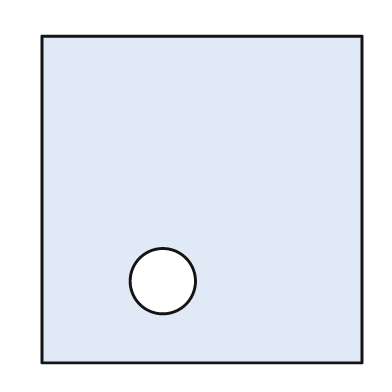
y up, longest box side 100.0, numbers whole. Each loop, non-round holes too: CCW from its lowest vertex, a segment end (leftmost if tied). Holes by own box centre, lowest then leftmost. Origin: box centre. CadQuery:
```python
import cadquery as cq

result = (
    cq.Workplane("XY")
    .moveTo(-49.0, -50.0)
    .lineTo(49.0, -50.0)
    .lineTo(49.0, 50.0)
    .lineTo(-49.0, 50.0)
    .close()
    .moveTo(-12.0, -25.0)
    .circle(10.0)
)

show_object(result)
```